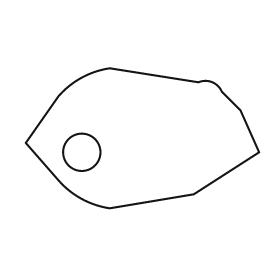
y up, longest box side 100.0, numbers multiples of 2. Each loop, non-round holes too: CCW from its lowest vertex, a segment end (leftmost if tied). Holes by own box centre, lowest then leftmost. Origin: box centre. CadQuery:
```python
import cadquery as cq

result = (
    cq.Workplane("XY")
    .moveTo(-14.0, -30.0)
    .lineTo(22.0, -24.0)
    .lineTo(50.0, -6.0)
    .lineTo(42.0, 12.0)
    .lineTo(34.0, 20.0)
    .threePointArc((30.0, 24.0), (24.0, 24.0))
    .lineTo(-14.0, 30.0)
    .threePointArc((-26.0, 26.0), (-36.0, 18.0))
    .lineTo(-50.0, -2.0)
    .lineTo(-36.0, -18.0)
    .threePointArc((-26.0, -26.0), (-14.0, -30.0))
    .close()
    .moveTo(-26.0, -6.0)
    .circle(8.0)
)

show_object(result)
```